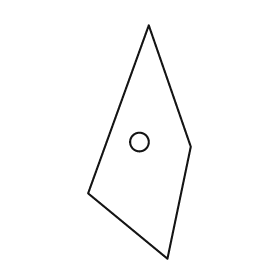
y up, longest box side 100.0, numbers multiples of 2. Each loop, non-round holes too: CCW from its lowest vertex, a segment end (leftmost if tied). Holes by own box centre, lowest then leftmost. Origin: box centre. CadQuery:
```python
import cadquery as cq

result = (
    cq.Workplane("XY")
    .moveTo(12.0, -50.0)
    .lineTo(22.0, -2.0)
    .lineTo(4.0, 50.0)
    .lineTo(-22.0, -22.0)
    .close()
    .moveTo(0.0, 0.0)
    .circle(4.0)
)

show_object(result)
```